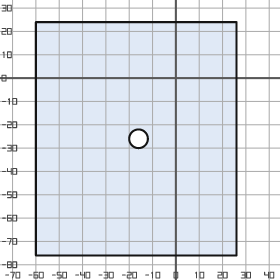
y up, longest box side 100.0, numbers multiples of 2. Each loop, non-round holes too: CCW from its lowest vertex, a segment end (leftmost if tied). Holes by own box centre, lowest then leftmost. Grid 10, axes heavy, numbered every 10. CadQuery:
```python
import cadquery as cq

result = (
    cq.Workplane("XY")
    .moveTo(-60.0, -76.0)
    .lineTo(26.0, -76.0)
    .lineTo(26.0, 24.0)
    .lineTo(-60.0, 24.0)
    .close()
    .moveTo(-16.0, -26.0)
    .circle(4.0)
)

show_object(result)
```